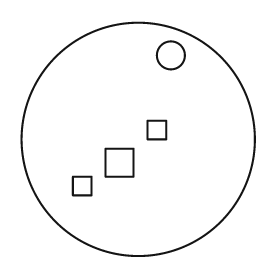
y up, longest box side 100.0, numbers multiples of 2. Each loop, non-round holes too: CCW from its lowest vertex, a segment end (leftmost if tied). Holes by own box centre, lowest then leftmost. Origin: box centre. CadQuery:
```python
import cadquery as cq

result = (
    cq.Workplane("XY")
    .moveTo(0.0, 0.0)
    .circle(50.0)
    .moveTo(-28.0, -24.0)
    .lineTo(-20.0, -24.0)
    .lineTo(-20.0, -16.0)
    .lineTo(-28.0, -16.0)
    .close()
    .moveTo(-14.0, -16.0)
    .lineTo(-2.0, -16.0)
    .lineTo(-2.0, -4.0)
    .lineTo(-14.0, -4.0)
    .close()
    .moveTo(4.0, 0.0)
    .lineTo(12.0, 0.0)
    .lineTo(12.0, 8.0)
    .lineTo(4.0, 8.0)
    .close()
    .moveTo(14.0, 36.0)
    .circle(6.0)
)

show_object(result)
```